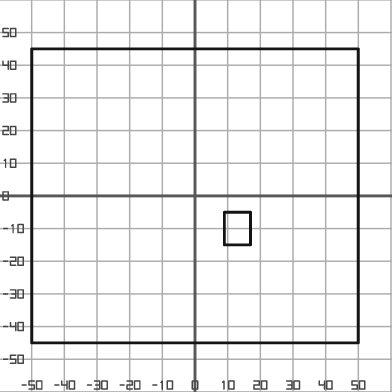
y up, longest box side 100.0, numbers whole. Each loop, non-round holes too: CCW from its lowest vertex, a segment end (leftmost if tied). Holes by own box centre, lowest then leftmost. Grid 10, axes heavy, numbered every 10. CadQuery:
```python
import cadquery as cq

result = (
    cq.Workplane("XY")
    .moveTo(-50.0, -45.0)
    .lineTo(50.0, -45.0)
    .lineTo(50.0, 45.0)
    .lineTo(-50.0, 45.0)
    .close()
    .moveTo(9.0, -15.0)
    .lineTo(17.0, -15.0)
    .lineTo(17.0, -5.0)
    .lineTo(9.0, -5.0)
    .close()
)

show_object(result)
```